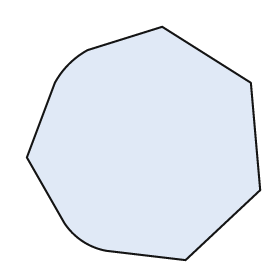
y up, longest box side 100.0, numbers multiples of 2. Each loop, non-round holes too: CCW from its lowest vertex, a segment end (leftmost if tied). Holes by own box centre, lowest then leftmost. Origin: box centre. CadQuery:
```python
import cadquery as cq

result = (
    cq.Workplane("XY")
    .moveTo(18.0, -50.0)
    .lineTo(50.0, -20.0)
    .lineTo(46.0, 26.0)
    .lineTo(8.0, 50.0)
    .lineTo(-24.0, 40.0)
    .threePointArc((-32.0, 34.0), (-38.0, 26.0))
    .lineTo(-50.0, -6.0)
    .lineTo(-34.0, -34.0)
    .threePointArc((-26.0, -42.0), (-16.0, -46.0))
    .close()
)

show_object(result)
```